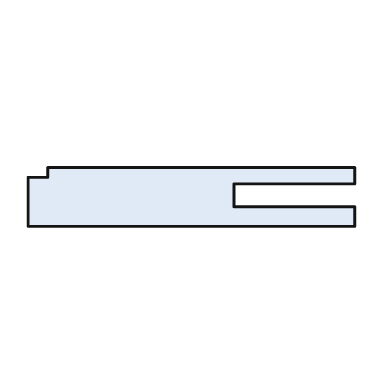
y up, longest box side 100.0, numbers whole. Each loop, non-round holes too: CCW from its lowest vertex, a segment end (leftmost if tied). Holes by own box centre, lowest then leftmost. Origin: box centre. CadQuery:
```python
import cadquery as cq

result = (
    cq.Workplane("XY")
    .moveTo(-50.0, -9.0)
    .lineTo(50.0, -9.0)
    .lineTo(50.0, -3.0)
    .lineTo(13.0, -3.0)
    .lineTo(13.0, 4.0)
    .lineTo(50.0, 4.0)
    .lineTo(50.0, 9.0)
    .lineTo(-44.0, 9.0)
    .lineTo(-44.0, 6.0)
    .lineTo(-50.0, 6.0)
    .close()
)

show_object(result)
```